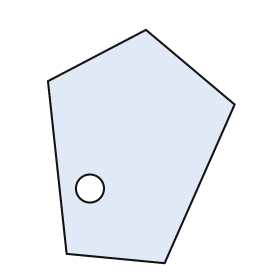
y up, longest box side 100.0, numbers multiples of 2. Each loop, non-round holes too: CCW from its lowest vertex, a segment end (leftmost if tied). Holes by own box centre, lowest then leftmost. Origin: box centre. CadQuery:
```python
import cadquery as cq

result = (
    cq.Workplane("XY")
    .moveTo(10.0, -50.0)
    .lineTo(40.0, 18.0)
    .lineTo(2.0, 50.0)
    .lineTo(-40.0, 28.0)
    .lineTo(-32.0, -46.0)
    .close()
    .moveTo(-22.0, -18.0)
    .circle(6.0)
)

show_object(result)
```